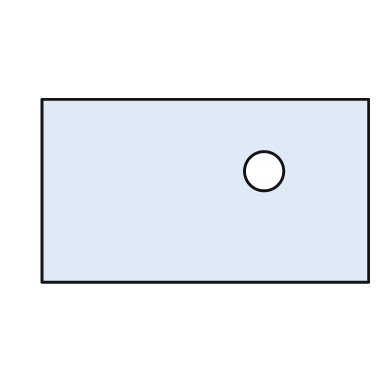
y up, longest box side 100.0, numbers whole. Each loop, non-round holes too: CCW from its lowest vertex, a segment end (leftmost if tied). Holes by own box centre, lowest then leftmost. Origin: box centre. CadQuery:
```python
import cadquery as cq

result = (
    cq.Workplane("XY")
    .moveTo(-50.0, -28.0)
    .lineTo(50.0, -28.0)
    .lineTo(50.0, 28.0)
    .lineTo(-50.0, 28.0)
    .close()
    .moveTo(18.0, 6.0)
    .circle(6.0)
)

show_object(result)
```